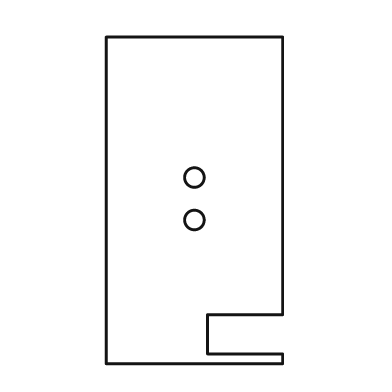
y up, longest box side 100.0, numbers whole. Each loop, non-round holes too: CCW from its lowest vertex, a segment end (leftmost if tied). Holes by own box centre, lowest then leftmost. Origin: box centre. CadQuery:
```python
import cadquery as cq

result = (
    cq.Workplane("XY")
    .moveTo(-27.0, -50.0)
    .lineTo(27.0, -50.0)
    .lineTo(27.0, -47.0)
    .lineTo(4.0, -47.0)
    .lineTo(4.0, -35.0)
    .lineTo(27.0, -35.0)
    .lineTo(27.0, 50.0)
    .lineTo(-27.0, 50.0)
    .close()
    .moveTo(0.0, -6.0)
    .circle(3.0)
    .moveTo(0.0, 7.0)
    .circle(3.0)
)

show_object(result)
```